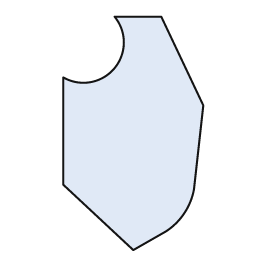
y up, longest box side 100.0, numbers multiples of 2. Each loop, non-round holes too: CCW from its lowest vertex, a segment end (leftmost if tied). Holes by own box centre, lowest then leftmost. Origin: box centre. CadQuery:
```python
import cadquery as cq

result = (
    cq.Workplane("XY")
    .moveTo(0.0, -50.0)
    .lineTo(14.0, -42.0)
    .threePointArc((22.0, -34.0), (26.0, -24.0))
    .lineTo(30.0, 12.0)
    .lineTo(12.0, 50.0)
    .lineTo(-8.0, 50.0)
    .threePointArc((-8.0, 28.0), (-30.0, 24.0))
    .lineTo(-30.0, -22.0)
    .close()
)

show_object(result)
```